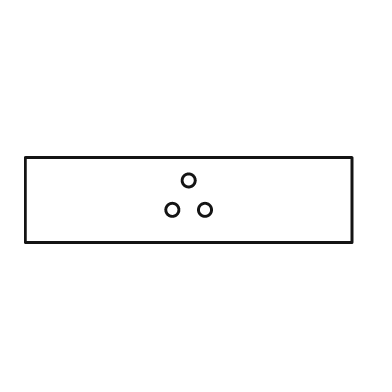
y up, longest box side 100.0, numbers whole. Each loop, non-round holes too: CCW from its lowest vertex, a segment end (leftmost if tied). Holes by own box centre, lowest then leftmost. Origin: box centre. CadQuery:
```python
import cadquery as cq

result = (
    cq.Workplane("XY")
    .moveTo(-50.0, -13.0)
    .lineTo(50.0, -13.0)
    .lineTo(50.0, 13.0)
    .lineTo(-50.0, 13.0)
    .close()
    .moveTo(-5.0, -3.0)
    .circle(2.0)
    .moveTo(5.0, -3.0)
    .circle(2.0)
    .moveTo(0.0, 6.0)
    .circle(2.0)
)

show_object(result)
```